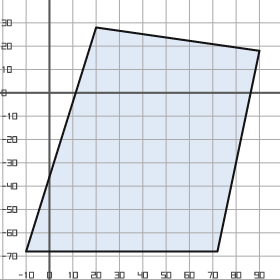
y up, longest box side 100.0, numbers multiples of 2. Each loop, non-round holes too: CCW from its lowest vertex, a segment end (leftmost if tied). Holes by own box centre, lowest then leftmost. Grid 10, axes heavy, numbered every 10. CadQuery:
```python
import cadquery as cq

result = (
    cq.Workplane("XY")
    .moveTo(-10.0, -68.0)
    .lineTo(72.0, -68.0)
    .lineTo(90.0, 18.0)
    .lineTo(20.0, 28.0)
    .close()
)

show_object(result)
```